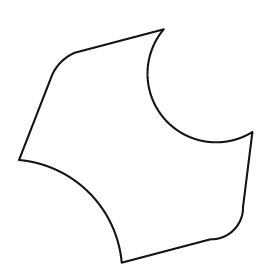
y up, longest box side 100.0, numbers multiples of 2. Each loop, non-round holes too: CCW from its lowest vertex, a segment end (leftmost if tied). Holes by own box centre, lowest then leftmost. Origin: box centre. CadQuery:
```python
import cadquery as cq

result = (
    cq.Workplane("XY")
    .moveTo(-6.0, -50.0)
    .lineTo(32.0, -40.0)
    .threePointArc((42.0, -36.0), (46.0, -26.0))
    .lineTo(50.0, 6.0)
    .threePointArc((12.0, 12.0), (12.0, 50.0))
    .lineTo(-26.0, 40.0)
    .threePointArc((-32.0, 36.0), (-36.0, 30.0))
    .lineTo(-50.0, -6.0)
    .threePointArc((-20.0, -20.0), (-6.0, -50.0))
    .close()
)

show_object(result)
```